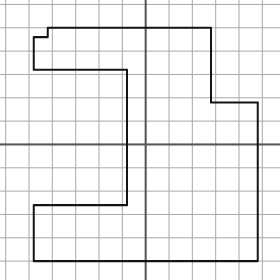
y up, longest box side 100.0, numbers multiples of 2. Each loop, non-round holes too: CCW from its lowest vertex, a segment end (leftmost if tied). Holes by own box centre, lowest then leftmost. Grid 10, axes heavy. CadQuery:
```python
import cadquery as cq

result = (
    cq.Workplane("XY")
    .moveTo(-48.0, -50.0)
    .lineTo(48.0, -50.0)
    .lineTo(48.0, 18.0)
    .lineTo(28.0, 18.0)
    .lineTo(28.0, 50.0)
    .lineTo(-42.0, 50.0)
    .lineTo(-42.0, 46.0)
    .lineTo(-48.0, 46.0)
    .lineTo(-48.0, 32.0)
    .lineTo(-8.0, 32.0)
    .lineTo(-8.0, -26.0)
    .lineTo(-48.0, -26.0)
    .close()
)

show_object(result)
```